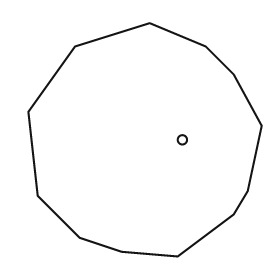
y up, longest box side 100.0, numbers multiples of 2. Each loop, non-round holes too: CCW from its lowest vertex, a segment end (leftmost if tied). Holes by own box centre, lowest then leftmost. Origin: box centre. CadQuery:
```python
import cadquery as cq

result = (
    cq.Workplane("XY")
    .moveTo(14.0, -50.0)
    .lineTo(38.0, -32.0)
    .lineTo(44.0, -22.0)
    .lineTo(50.0, 6.0)
    .lineTo(38.0, 28.0)
    .lineTo(26.0, 40.0)
    .lineTo(2.0, 50.0)
    .lineTo(-30.0, 40.0)
    .lineTo(-50.0, 12.0)
    .lineTo(-46.0, -24.0)
    .lineTo(-28.0, -42.0)
    .lineTo(-10.0, -48.0)
    .close()
    .moveTo(16.0, 0.0)
    .circle(2.0)
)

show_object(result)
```